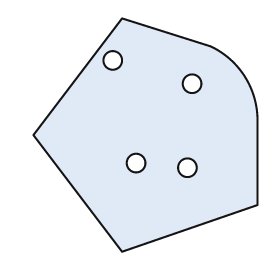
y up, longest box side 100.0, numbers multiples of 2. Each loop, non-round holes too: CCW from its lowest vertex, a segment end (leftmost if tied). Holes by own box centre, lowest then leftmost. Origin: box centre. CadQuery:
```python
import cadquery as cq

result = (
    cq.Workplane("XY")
    .moveTo(-10.0, -50.0)
    .lineTo(48.0, -30.0)
    .lineTo(48.0, 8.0)
    .threePointArc((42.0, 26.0), (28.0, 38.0))
    .lineTo(-10.0, 50.0)
    .lineTo(-48.0, 0.0)
    .close()
    .moveTo(18.0, -14.0)
    .circle(4.0)
    .moveTo(-4.0, -12.0)
    .circle(4.0)
    .moveTo(20.0, 22.0)
    .circle(4.0)
    .moveTo(-14.0, 32.0)
    .circle(4.0)
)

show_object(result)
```